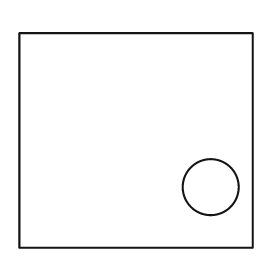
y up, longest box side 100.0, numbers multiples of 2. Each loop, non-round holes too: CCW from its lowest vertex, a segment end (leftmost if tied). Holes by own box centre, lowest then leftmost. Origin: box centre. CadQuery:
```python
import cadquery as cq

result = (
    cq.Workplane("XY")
    .moveTo(-50.0, -46.0)
    .lineTo(50.0, -46.0)
    .lineTo(50.0, 46.0)
    .lineTo(-50.0, 46.0)
    .close()
    .moveTo(32.0, -20.0)
    .circle(12.0)
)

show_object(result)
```